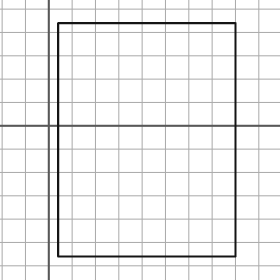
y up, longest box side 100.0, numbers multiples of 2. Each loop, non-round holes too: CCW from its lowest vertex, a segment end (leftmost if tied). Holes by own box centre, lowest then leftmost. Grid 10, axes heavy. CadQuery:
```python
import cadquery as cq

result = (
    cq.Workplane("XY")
    .moveTo(4.0, -56.0)
    .lineTo(80.0, -56.0)
    .lineTo(80.0, 44.0)
    .lineTo(4.0, 44.0)
    .close()
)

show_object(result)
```